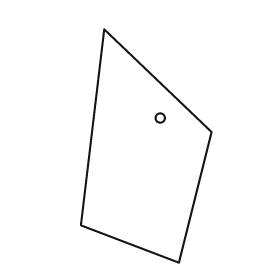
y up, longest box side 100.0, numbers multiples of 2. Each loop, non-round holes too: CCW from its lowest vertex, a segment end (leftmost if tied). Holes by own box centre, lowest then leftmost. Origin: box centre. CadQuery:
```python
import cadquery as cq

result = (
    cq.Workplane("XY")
    .moveTo(14.0, -50.0)
    .lineTo(28.0, 6.0)
    .lineTo(-18.0, 50.0)
    .lineTo(-28.0, -34.0)
    .close()
    .moveTo(6.0, 12.0)
    .circle(2.0)
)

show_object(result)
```